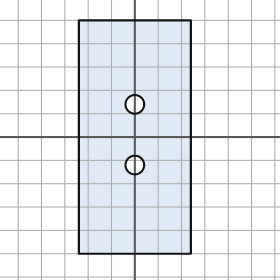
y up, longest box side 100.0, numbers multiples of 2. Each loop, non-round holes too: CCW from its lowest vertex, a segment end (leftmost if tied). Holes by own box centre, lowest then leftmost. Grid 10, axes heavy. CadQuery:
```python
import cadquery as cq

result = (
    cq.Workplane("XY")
    .moveTo(-24.0, -50.0)
    .lineTo(24.0, -50.0)
    .lineTo(24.0, 50.0)
    .lineTo(-24.0, 50.0)
    .close()
    .moveTo(0.0, -12.0)
    .circle(4.0)
    .moveTo(0.0, 14.0)
    .circle(4.0)
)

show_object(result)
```